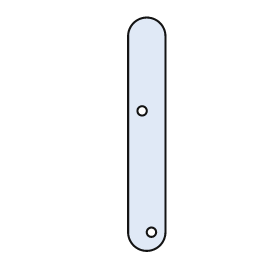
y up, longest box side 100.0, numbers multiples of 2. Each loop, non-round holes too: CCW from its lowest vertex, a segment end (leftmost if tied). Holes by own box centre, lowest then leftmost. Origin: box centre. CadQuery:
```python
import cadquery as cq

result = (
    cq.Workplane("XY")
    .moveTo(-8.0, -42.0)
    .threePointArc((0.0, -50.0), (8.0, -42.0))
    .lineTo(8.0, 42.0)
    .threePointArc((0.0, 50.0), (-8.0, 42.0))
    .close()
    .moveTo(2.0, -42.0)
    .circle(2.0)
    .moveTo(-2.0, 10.0)
    .circle(2.0)
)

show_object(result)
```